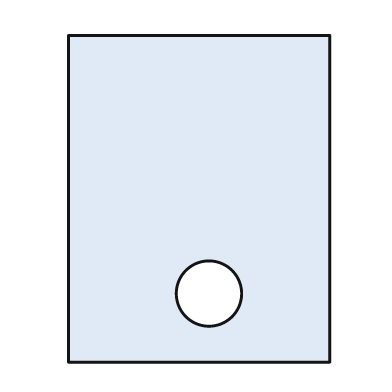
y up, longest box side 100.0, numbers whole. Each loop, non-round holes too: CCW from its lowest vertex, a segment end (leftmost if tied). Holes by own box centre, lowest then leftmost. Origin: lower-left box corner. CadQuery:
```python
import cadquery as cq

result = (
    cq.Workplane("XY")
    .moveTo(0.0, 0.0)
    .lineTo(80.0, 0.0)
    .lineTo(80.0, 100.0)
    .lineTo(0.0, 100.0)
    .close()
    .moveTo(43.0, 21.0)
    .circle(10.0)
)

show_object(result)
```